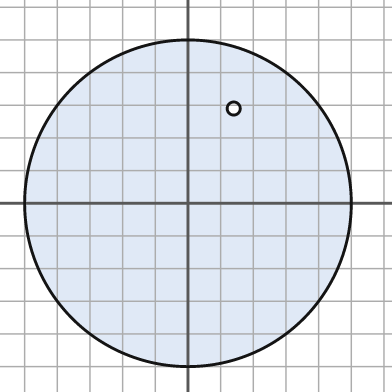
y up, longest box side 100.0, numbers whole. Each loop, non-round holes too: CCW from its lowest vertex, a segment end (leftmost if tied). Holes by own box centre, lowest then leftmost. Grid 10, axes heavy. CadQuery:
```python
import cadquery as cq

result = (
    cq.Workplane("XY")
    .moveTo(0.0, 0.0)
    .circle(50.0)
    .moveTo(14.0, 29.0)
    .circle(2.0)
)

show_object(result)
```